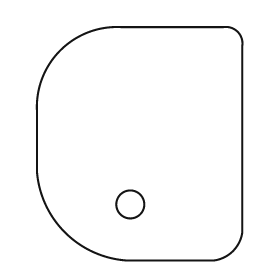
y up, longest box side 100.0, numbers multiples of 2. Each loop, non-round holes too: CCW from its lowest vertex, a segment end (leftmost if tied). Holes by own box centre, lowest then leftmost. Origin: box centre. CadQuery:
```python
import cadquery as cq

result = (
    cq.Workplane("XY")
    .moveTo(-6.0, -50.0)
    .lineTo(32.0, -50.0)
    .threePointArc((40.0, -46.0), (44.0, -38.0))
    .lineTo(44.0, 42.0)
    .threePointArc((42.0, 48.0), (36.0, 50.0))
    .lineTo(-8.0, 50.0)
    .threePointArc((-34.0, 40.0), (-44.0, 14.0))
    .lineTo(-44.0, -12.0)
    .threePointArc((-32.0, -38.0), (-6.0, -50.0))
    .close()
    .moveTo(-4.0, -26.0)
    .circle(6.0)
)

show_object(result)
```